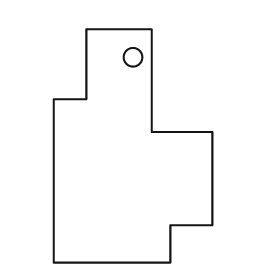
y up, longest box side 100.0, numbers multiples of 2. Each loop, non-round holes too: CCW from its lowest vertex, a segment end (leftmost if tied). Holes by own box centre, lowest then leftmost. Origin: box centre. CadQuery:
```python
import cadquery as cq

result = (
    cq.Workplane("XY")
    .moveTo(-34.0, -50.0)
    .lineTo(16.0, -50.0)
    .lineTo(16.0, -34.0)
    .lineTo(34.0, -34.0)
    .lineTo(34.0, 6.0)
    .lineTo(8.0, 6.0)
    .lineTo(8.0, 50.0)
    .lineTo(-20.0, 50.0)
    .lineTo(-20.0, 20.0)
    .lineTo(-34.0, 20.0)
    .close()
    .moveTo(0.0, 38.0)
    .circle(4.0)
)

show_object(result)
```